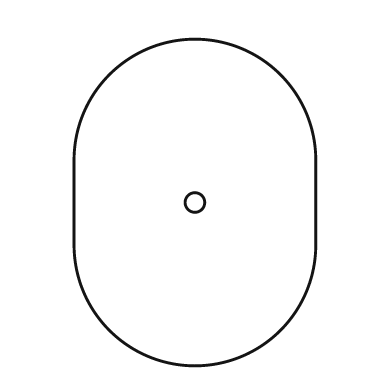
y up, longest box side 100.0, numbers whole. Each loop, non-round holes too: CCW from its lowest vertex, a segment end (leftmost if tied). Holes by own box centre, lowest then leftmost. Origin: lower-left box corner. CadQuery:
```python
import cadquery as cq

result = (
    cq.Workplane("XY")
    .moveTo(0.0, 37.0)
    .threePointArc((37.0, 0.0), (74.0, 37.0))
    .lineTo(74.0, 63.0)
    .threePointArc((37.0, 100.0), (0.0, 63.0))
    .close()
    .moveTo(37.0, 50.0)
    .circle(3.0)
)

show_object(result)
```